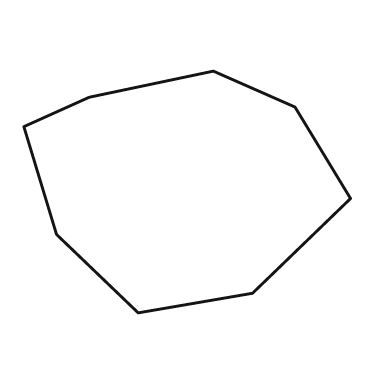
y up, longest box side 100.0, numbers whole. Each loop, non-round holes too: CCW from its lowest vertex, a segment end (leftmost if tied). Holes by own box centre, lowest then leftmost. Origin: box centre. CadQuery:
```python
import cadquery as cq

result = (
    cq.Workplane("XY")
    .moveTo(-15.0, -37.0)
    .lineTo(20.0, -31.0)
    .lineTo(50.0, -2.0)
    .lineTo(33.0, 26.0)
    .lineTo(8.0, 37.0)
    .lineTo(-30.0, 29.0)
    .lineTo(-50.0, 20.0)
    .lineTo(-40.0, -13.0)
    .close()
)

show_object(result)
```